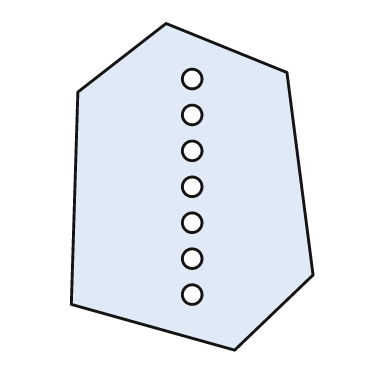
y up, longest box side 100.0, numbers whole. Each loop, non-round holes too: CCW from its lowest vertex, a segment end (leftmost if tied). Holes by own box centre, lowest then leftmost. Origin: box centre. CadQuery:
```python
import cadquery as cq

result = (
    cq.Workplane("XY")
    .moveTo(13.0, -50.0)
    .lineTo(37.0, -27.0)
    .lineTo(29.0, 35.0)
    .lineTo(-8.0, 50.0)
    .lineTo(-35.0, 29.0)
    .lineTo(-37.0, -36.0)
    .close()
    .moveTo(0.0, -33.0)
    .circle(3.0)
    .moveTo(0.0, -22.0)
    .circle(3.0)
    .moveTo(0.0, -11.0)
    .circle(3.0)
    .moveTo(0.0, 0.0)
    .circle(3.0)
    .moveTo(0.0, 11.0)
    .circle(3.0)
    .moveTo(0.0, 22.0)
    .circle(3.0)
    .moveTo(0.0, 33.0)
    .circle(3.0)
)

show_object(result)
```